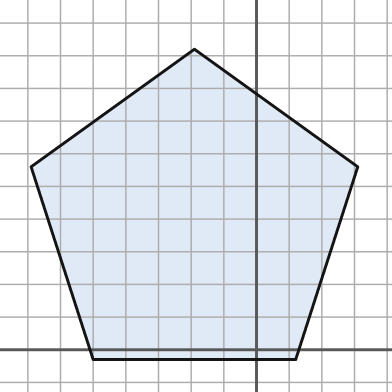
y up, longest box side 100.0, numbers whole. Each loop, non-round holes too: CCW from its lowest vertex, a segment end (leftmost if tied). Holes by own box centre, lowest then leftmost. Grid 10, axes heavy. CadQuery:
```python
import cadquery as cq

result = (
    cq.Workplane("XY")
    .moveTo(-50.0, -3.0)
    .lineTo(12.0, -3.0)
    .lineTo(31.0, 56.0)
    .lineTo(-19.0, 92.0)
    .lineTo(-69.0, 56.0)
    .close()
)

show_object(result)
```